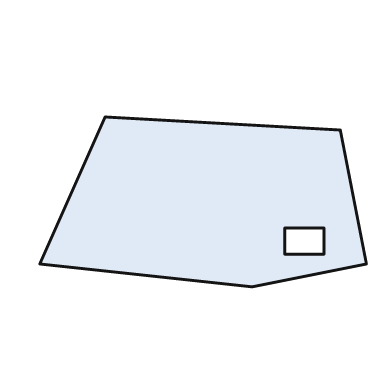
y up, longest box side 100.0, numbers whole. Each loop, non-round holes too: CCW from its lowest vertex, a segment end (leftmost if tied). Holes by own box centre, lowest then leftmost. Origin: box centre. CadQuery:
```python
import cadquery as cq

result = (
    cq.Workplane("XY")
    .moveTo(15.0, -26.0)
    .lineTo(50.0, -19.0)
    .lineTo(42.0, 22.0)
    .lineTo(-30.0, 26.0)
    .lineTo(-50.0, -19.0)
    .close()
    .moveTo(25.0, -16.0)
    .lineTo(37.0, -16.0)
    .lineTo(37.0, -8.0)
    .lineTo(25.0, -8.0)
    .close()
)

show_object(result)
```